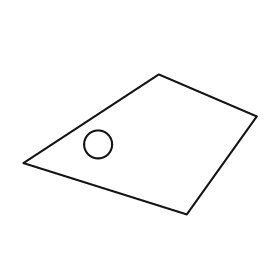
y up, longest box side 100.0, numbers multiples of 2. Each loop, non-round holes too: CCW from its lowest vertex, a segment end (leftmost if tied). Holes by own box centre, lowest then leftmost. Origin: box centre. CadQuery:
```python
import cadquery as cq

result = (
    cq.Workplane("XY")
    .moveTo(20.0, -30.0)
    .lineTo(50.0, 12.0)
    .lineTo(8.0, 30.0)
    .lineTo(-50.0, -8.0)
    .close()
    .moveTo(-18.0, 0.0)
    .circle(6.0)
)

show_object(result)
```